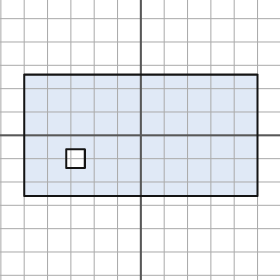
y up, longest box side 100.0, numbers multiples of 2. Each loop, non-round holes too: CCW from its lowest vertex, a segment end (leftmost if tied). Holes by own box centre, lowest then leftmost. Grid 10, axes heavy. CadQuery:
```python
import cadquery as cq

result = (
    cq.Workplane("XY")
    .moveTo(-50.0, -26.0)
    .lineTo(50.0, -26.0)
    .lineTo(50.0, 26.0)
    .lineTo(-50.0, 26.0)
    .close()
    .moveTo(-32.0, -14.0)
    .lineTo(-24.0, -14.0)
    .lineTo(-24.0, -6.0)
    .lineTo(-32.0, -6.0)
    .close()
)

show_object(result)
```